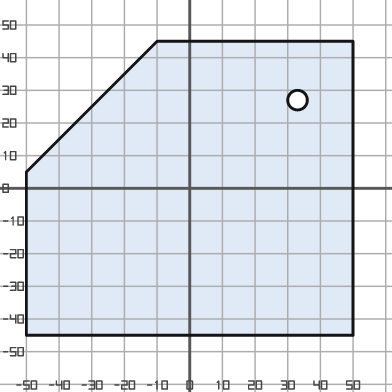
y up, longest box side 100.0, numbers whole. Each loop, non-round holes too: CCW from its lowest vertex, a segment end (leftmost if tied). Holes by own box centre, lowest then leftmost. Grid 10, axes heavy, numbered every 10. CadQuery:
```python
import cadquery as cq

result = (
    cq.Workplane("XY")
    .moveTo(-50.0, -45.0)
    .lineTo(50.0, -45.0)
    .lineTo(50.0, 45.0)
    .lineTo(-10.0, 45.0)
    .lineTo(-50.0, 5.0)
    .close()
    .moveTo(33.0, 27.0)
    .circle(3.0)
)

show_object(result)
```